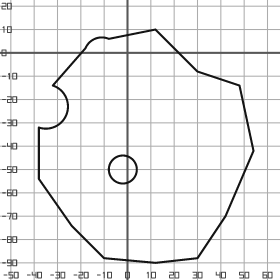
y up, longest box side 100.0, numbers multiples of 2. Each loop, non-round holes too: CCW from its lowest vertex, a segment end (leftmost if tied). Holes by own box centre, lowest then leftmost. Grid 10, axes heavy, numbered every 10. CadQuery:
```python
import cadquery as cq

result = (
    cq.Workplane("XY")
    .moveTo(12.0, -90.0)
    .lineTo(30.0, -88.0)
    .lineTo(42.0, -70.0)
    .lineTo(54.0, -42.0)
    .lineTo(48.0, -14.0)
    .lineTo(30.0, -8.0)
    .lineTo(12.0, 10.0)
    .lineTo(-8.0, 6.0)
    .threePointArc((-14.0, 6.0), (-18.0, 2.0))
    .lineTo(-32.0, -14.0)
    .threePointArc((-26.0, -26.0), (-38.0, -32.0))
    .lineTo(-38.0, -54.0)
    .lineTo(-24.0, -74.0)
    .lineTo(-10.0, -88.0)
    .close()
    .moveTo(-2.0, -50.0)
    .circle(6.0)
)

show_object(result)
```